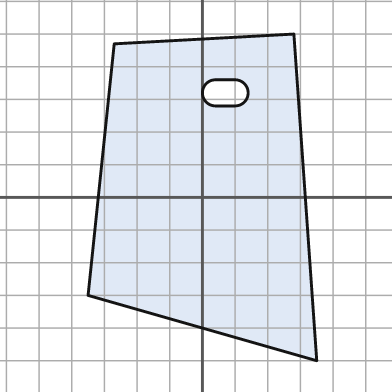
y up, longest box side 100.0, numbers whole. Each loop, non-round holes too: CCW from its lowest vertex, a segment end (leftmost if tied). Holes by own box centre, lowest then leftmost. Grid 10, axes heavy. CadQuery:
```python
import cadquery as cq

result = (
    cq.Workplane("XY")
    .moveTo(35.0, -50.0)
    .lineTo(28.0, 50.0)
    .lineTo(-27.0, 47.0)
    .lineTo(-35.0, -30.0)
    .close()
    .moveTo(4.0, 28.0)
    .lineTo(10.0, 28.0)
    .threePointArc((14.0, 32.0), (10.0, 36.0))
    .lineTo(4.0, 36.0)
    .threePointArc((0.0, 32.0), (4.0, 28.0))
    .close()
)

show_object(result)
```